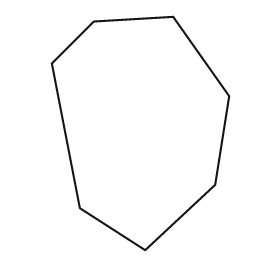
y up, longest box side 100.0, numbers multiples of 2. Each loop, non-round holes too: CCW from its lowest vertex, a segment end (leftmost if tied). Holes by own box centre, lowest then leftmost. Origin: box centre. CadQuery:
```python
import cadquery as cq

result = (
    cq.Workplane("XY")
    .moveTo(2.0, -50.0)
    .lineTo(32.0, -22.0)
    .lineTo(38.0, 16.0)
    .lineTo(14.0, 50.0)
    .lineTo(-20.0, 48.0)
    .lineTo(-38.0, 30.0)
    .lineTo(-26.0, -32.0)
    .close()
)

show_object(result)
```